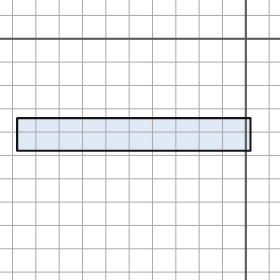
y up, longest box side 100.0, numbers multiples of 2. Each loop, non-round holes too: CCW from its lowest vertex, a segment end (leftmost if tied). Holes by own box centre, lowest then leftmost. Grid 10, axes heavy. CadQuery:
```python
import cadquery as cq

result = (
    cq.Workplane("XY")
    .moveTo(-98.0, -48.0)
    .lineTo(2.0, -48.0)
    .lineTo(2.0, -34.0)
    .lineTo(-98.0, -34.0)
    .close()
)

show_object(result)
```